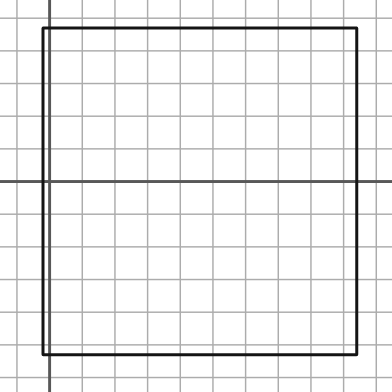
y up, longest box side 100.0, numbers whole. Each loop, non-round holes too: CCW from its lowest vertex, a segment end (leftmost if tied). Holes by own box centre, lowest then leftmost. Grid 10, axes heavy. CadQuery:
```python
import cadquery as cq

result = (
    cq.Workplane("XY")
    .moveTo(-2.0, -53.0)
    .lineTo(94.0, -53.0)
    .lineTo(94.0, 47.0)
    .lineTo(-2.0, 47.0)
    .close()
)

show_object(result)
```